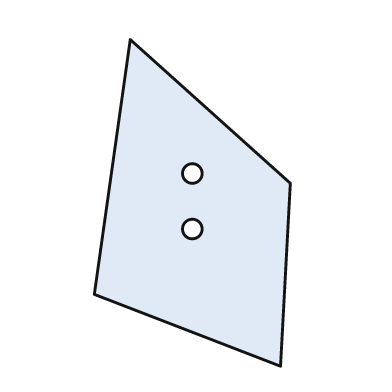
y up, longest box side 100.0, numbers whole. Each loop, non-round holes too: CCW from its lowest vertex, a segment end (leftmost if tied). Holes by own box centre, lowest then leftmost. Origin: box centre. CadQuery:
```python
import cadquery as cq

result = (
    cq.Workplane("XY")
    .moveTo(27.0, -50.0)
    .lineTo(30.0, 6.0)
    .lineTo(-19.0, 50.0)
    .lineTo(-30.0, -28.0)
    .close()
    .moveTo(0.0, -8.0)
    .circle(3.0)
    .moveTo(0.0, 9.0)
    .circle(3.0)
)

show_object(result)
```